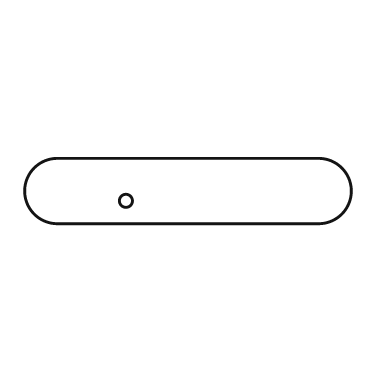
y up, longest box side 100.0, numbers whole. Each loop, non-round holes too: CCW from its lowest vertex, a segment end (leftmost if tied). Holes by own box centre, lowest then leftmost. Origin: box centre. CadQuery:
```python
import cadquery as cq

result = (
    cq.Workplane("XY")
    .moveTo(-40.0, -10.0)
    .lineTo(40.0, -10.0)
    .threePointArc((50.0, 0.0), (40.0, 10.0))
    .lineTo(-40.0, 10.0)
    .threePointArc((-50.0, 0.0), (-40.0, -10.0))
    .close()
    .moveTo(-19.0, -3.0)
    .circle(2.0)
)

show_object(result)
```